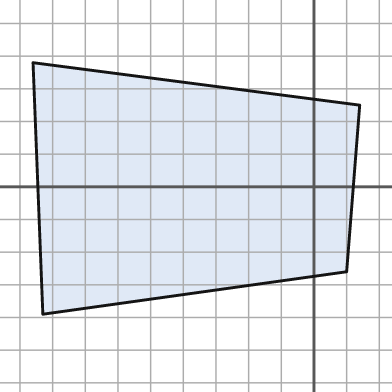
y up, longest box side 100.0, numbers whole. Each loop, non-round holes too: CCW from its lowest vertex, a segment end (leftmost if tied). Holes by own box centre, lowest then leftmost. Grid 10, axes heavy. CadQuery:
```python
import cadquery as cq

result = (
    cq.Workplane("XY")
    .moveTo(-83.0, -39.0)
    .lineTo(10.0, -26.0)
    .lineTo(14.0, 25.0)
    .lineTo(-86.0, 38.0)
    .close()
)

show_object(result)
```